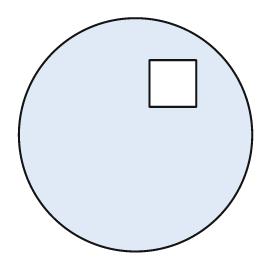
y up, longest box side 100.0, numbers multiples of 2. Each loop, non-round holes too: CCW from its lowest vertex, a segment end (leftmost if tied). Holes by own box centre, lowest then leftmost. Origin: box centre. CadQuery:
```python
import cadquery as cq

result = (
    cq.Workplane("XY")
    .moveTo(0.0, 0.0)
    .circle(50.0)
    .moveTo(6.0, 12.0)
    .lineTo(26.0, 12.0)
    .lineTo(26.0, 32.0)
    .lineTo(6.0, 32.0)
    .close()
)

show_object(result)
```